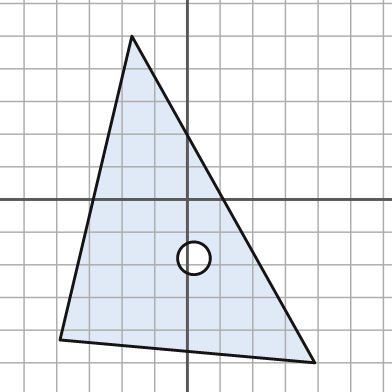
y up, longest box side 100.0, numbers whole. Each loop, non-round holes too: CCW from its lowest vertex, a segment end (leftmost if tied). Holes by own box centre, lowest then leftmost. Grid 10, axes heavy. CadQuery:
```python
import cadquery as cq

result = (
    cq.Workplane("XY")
    .moveTo(39.0, -50.0)
    .lineTo(-17.0, 50.0)
    .lineTo(-39.0, -43.0)
    .close()
    .moveTo(2.0, -18.0)
    .circle(5.0)
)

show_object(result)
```